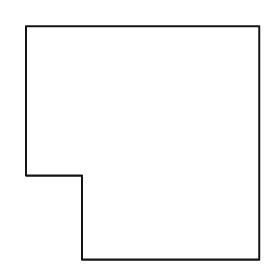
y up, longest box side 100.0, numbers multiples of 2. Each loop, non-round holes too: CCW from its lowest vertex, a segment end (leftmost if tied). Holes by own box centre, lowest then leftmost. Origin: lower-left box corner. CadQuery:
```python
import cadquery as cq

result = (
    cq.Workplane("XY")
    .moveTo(24.0, 0.0)
    .lineTo(100.0, 0.0)
    .lineTo(100.0, 100.0)
    .lineTo(0.0, 100.0)
    .lineTo(0.0, 36.0)
    .lineTo(24.0, 36.0)
    .close()
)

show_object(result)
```